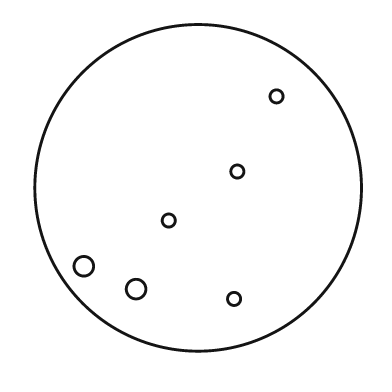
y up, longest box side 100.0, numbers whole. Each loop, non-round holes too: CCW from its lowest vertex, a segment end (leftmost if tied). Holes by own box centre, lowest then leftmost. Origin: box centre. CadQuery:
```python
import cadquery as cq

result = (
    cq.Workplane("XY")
    .moveTo(0.0, 0.0)
    .circle(50.0)
    .moveTo(11.0, -34.0)
    .circle(2.0)
    .moveTo(-19.0, -31.0)
    .circle(3.0)
    .moveTo(-35.0, -24.0)
    .circle(3.0)
    .moveTo(-9.0, -10.0)
    .circle(2.0)
    .moveTo(12.0, 5.0)
    .circle(2.0)
    .moveTo(24.0, 28.0)
    .circle(2.0)
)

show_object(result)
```